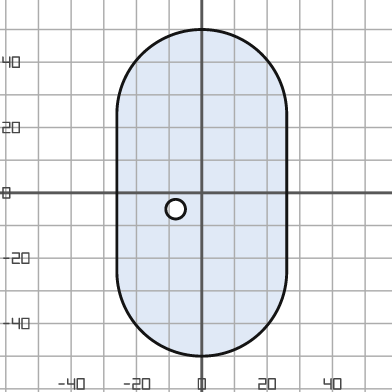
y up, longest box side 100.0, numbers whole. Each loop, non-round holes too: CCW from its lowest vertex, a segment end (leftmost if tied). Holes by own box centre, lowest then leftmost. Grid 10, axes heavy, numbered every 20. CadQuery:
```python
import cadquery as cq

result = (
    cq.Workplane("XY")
    .moveTo(-26.0, -24.0)
    .threePointArc((0.0, -50.0), (26.0, -24.0))
    .lineTo(26.0, 24.0)
    .threePointArc((0.0, 50.0), (-26.0, 24.0))
    .close()
    .moveTo(-8.0, -5.0)
    .circle(3.0)
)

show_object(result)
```